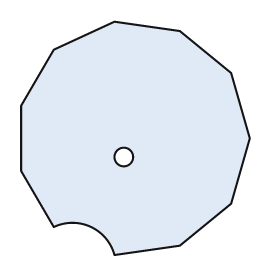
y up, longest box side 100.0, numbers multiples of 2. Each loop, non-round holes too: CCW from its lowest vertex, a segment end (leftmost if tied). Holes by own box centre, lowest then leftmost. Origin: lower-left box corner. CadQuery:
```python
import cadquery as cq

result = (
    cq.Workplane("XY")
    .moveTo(40.0, 0.0)
    .lineTo(68.0, 4.0)
    .lineTo(90.0, 22.0)
    .lineTo(98.0, 50.0)
    .lineTo(90.0, 78.0)
    .lineTo(68.0, 96.0)
    .lineTo(40.0, 100.0)
    .lineTo(14.0, 88.0)
    .lineTo(0.0, 64.0)
    .lineTo(0.0, 36.0)
    .lineTo(14.0, 12.0)
    .threePointArc((30.0, 12.0), (40.0, 0.0))
    .close()
    .moveTo(44.0, 42.0)
    .circle(4.0)
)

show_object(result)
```